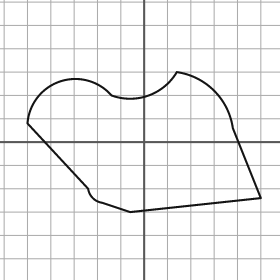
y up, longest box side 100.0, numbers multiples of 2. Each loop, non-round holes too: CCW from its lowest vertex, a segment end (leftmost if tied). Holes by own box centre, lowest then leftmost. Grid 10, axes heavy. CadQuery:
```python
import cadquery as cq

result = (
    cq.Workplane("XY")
    .moveTo(-6.0, -30.0)
    .lineTo(50.0, -24.0)
    .lineTo(38.0, 6.0)
    .threePointArc((30.0, 22.0), (14.0, 30.0))
    .threePointArc((2.0, 20.0), (-14.0, 20.0))
    .threePointArc((-36.0, 26.0), (-50.0, 8.0))
    .lineTo(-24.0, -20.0)
    .threePointArc((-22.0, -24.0), (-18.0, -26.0))
    .close()
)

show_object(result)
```